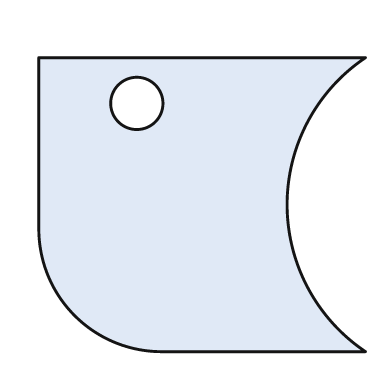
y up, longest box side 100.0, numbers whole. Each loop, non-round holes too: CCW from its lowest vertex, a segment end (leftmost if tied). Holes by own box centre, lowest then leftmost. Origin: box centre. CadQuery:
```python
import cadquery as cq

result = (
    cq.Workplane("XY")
    .moveTo(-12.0, -45.0)
    .lineTo(50.0, -45.0)
    .threePointArc((26.0, 0.0), (50.0, 45.0))
    .lineTo(-50.0, 45.0)
    .lineTo(-50.0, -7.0)
    .threePointArc((-39.0, -34.0), (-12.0, -45.0))
    .close()
    .moveTo(-20.0, 31.0)
    .circle(8.0)
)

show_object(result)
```